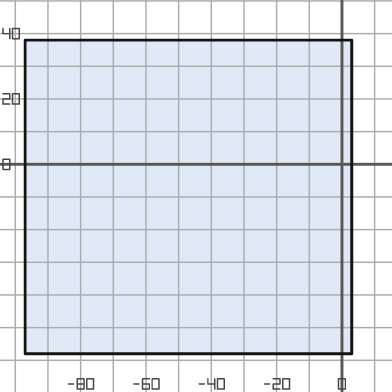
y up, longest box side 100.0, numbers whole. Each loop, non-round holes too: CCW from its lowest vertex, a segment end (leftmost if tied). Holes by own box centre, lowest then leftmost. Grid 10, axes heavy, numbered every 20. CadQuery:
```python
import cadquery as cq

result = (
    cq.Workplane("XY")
    .moveTo(-97.0, -58.0)
    .lineTo(3.0, -58.0)
    .lineTo(3.0, 38.0)
    .lineTo(-97.0, 38.0)
    .close()
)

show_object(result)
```